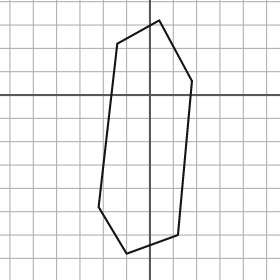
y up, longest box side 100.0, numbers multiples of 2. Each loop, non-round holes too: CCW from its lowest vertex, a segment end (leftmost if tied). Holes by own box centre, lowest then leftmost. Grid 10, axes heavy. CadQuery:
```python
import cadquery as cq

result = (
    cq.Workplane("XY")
    .moveTo(-10.0, -68.0)
    .lineTo(12.0, -60.0)
    .lineTo(18.0, 6.0)
    .lineTo(4.0, 32.0)
    .lineTo(-14.0, 22.0)
    .lineTo(-22.0, -48.0)
    .close()
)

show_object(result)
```